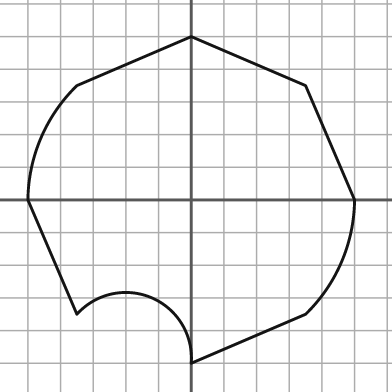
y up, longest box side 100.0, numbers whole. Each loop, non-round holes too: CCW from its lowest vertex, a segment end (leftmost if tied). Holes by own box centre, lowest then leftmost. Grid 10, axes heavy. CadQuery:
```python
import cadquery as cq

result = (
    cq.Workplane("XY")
    .moveTo(0.0, -50.0)
    .lineTo(35.0, -35.0)
    .threePointArc((46.0, -19.0), (50.0, 0.0))
    .lineTo(35.0, 35.0)
    .lineTo(0.0, 50.0)
    .lineTo(-35.0, 35.0)
    .threePointArc((-46.0, 19.0), (-50.0, 0.0))
    .lineTo(-35.0, -35.0)
    .threePointArc((-12.0, -30.0), (0.0, -50.0))
    .close()
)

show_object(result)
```